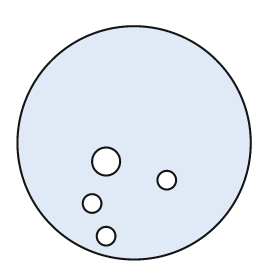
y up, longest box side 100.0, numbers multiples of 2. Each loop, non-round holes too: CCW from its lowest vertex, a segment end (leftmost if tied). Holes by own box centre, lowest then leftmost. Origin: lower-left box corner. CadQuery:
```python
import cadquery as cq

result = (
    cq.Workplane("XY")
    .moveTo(50.0, 50.0)
    .circle(50.0)
    .moveTo(38.0, 10.0)
    .circle(4.0)
    .moveTo(32.0, 24.0)
    .circle(4.0)
    .moveTo(64.0, 34.0)
    .circle(4.0)
    .moveTo(38.0, 42.0)
    .circle(6.0)
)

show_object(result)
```